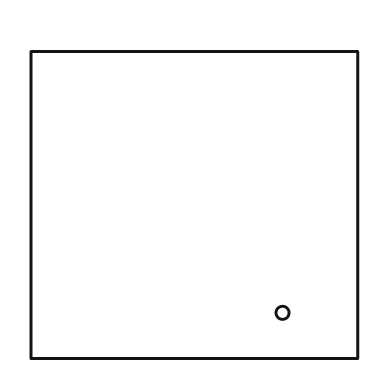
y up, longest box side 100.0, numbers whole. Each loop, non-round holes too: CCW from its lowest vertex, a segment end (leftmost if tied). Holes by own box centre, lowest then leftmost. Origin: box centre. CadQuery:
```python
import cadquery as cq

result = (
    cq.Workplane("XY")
    .moveTo(-50.0, -47.0)
    .lineTo(50.0, -47.0)
    .lineTo(50.0, 47.0)
    .lineTo(-50.0, 47.0)
    .close()
    .moveTo(27.0, -33.0)
    .circle(2.0)
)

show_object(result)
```